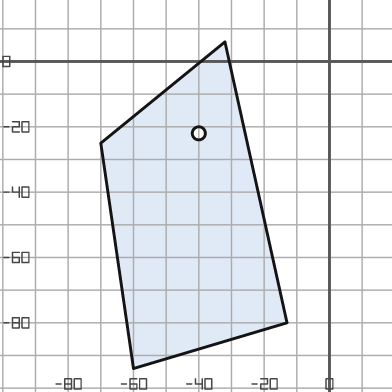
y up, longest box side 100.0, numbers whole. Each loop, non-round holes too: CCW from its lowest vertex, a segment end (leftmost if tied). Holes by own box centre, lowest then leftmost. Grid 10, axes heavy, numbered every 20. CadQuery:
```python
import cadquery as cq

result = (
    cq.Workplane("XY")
    .moveTo(-60.0, -94.0)
    .lineTo(-13.0, -80.0)
    .lineTo(-32.0, 6.0)
    .lineTo(-70.0, -25.0)
    .close()
    .moveTo(-40.0, -22.0)
    .circle(2.0)
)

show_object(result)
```